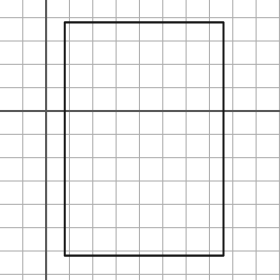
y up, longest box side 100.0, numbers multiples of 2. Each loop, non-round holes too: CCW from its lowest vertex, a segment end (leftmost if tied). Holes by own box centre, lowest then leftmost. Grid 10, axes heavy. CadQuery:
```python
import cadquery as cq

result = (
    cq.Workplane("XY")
    .moveTo(8.0, -62.0)
    .lineTo(76.0, -62.0)
    .lineTo(76.0, 38.0)
    .lineTo(8.0, 38.0)
    .close()
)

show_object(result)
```